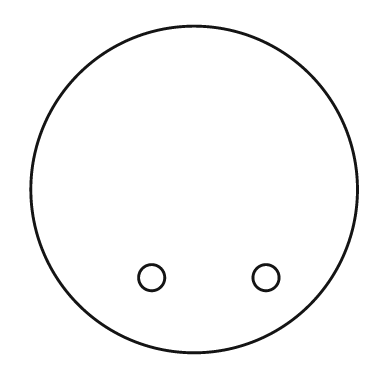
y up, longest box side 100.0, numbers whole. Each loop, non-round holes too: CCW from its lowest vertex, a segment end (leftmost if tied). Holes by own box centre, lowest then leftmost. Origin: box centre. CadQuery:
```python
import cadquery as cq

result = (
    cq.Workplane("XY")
    .moveTo(0.0, 0.0)
    .circle(50.0)
    .moveTo(-13.0, -27.0)
    .circle(4.0)
    .moveTo(22.0, -27.0)
    .circle(4.0)
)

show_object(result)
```